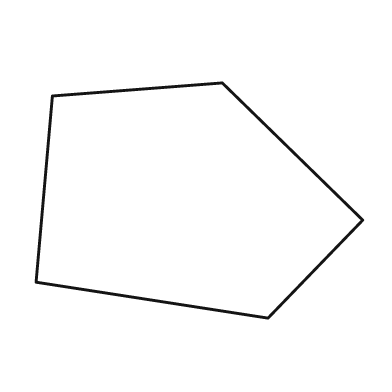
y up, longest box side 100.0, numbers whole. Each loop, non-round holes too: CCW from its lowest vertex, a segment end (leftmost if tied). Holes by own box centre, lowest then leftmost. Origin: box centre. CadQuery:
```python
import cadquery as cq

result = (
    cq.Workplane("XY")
    .moveTo(21.0, -36.0)
    .lineTo(50.0, -6.0)
    .lineTo(7.0, 36.0)
    .lineTo(-45.0, 32.0)
    .lineTo(-50.0, -25.0)
    .close()
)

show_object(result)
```